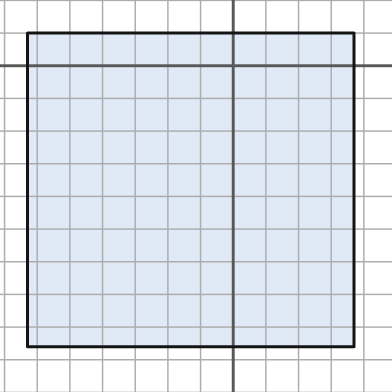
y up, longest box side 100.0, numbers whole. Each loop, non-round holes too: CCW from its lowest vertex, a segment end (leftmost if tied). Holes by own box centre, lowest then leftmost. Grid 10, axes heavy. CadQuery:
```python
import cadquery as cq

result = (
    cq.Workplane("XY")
    .moveTo(-63.0, -86.0)
    .lineTo(37.0, -86.0)
    .lineTo(37.0, 10.0)
    .lineTo(-63.0, 10.0)
    .close()
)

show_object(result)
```